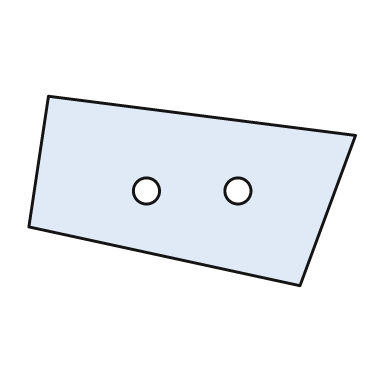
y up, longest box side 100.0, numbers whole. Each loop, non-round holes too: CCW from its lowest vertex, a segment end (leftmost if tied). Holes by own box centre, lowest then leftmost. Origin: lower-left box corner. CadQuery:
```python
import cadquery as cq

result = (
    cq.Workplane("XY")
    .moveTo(83.0, 0.0)
    .lineTo(100.0, 46.0)
    .lineTo(6.0, 58.0)
    .lineTo(0.0, 18.0)
    .close()
    .moveTo(36.0, 29.0)
    .circle(4.0)
    .moveTo(64.0, 29.0)
    .circle(4.0)
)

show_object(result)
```